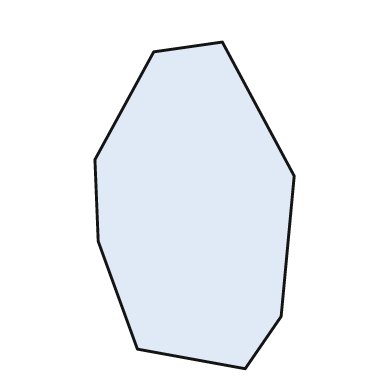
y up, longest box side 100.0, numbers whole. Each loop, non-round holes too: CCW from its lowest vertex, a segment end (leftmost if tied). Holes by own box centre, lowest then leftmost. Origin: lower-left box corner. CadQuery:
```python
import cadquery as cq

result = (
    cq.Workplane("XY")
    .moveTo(46.0, 0.0)
    .lineTo(57.0, 16.0)
    .lineTo(61.0, 59.0)
    .lineTo(39.0, 100.0)
    .lineTo(18.0, 97.0)
    .lineTo(0.0, 64.0)
    .lineTo(1.0, 39.0)
    .lineTo(13.0, 6.0)
    .close()
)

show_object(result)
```